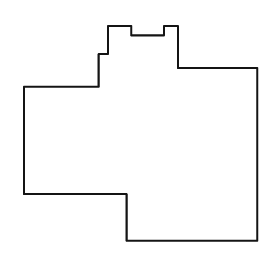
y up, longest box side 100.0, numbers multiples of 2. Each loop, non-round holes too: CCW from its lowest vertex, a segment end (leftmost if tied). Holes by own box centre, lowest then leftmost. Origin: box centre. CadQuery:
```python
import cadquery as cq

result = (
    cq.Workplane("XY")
    .moveTo(-6.0, -46.0)
    .lineTo(50.0, -46.0)
    .lineTo(50.0, 28.0)
    .lineTo(16.0, 28.0)
    .lineTo(16.0, 46.0)
    .lineTo(10.0, 46.0)
    .lineTo(10.0, 42.0)
    .lineTo(-4.0, 42.0)
    .lineTo(-4.0, 46.0)
    .lineTo(-14.0, 46.0)
    .lineTo(-14.0, 34.0)
    .lineTo(-18.0, 34.0)
    .lineTo(-18.0, 20.0)
    .lineTo(-50.0, 20.0)
    .lineTo(-50.0, -26.0)
    .lineTo(-6.0, -26.0)
    .close()
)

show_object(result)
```